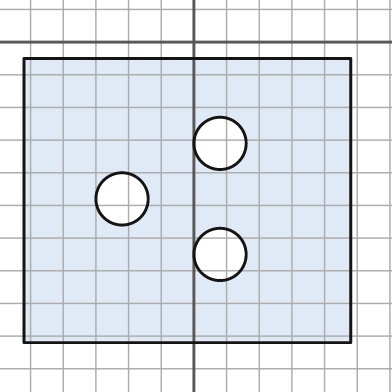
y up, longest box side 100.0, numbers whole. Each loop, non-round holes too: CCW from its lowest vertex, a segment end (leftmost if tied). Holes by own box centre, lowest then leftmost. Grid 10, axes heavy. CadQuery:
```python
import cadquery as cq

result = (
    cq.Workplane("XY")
    .moveTo(-52.0, -92.0)
    .lineTo(48.0, -92.0)
    .lineTo(48.0, -5.0)
    .lineTo(-52.0, -5.0)
    .close()
    .moveTo(8.0, -65.0)
    .circle(8.0)
    .moveTo(-22.0, -48.0)
    .circle(8.0)
    .moveTo(8.0, -31.0)
    .circle(8.0)
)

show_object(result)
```